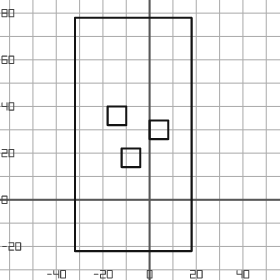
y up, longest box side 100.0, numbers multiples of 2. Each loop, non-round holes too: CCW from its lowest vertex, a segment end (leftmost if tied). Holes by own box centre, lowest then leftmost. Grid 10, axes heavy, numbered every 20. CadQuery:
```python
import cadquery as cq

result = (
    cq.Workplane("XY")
    .moveTo(-32.0, -22.0)
    .lineTo(18.0, -22.0)
    .lineTo(18.0, 78.0)
    .lineTo(-32.0, 78.0)
    .close()
    .moveTo(-12.0, 14.0)
    .lineTo(-4.0, 14.0)
    .lineTo(-4.0, 22.0)
    .lineTo(-12.0, 22.0)
    .close()
    .moveTo(0.0, 26.0)
    .lineTo(8.0, 26.0)
    .lineTo(8.0, 34.0)
    .lineTo(0.0, 34.0)
    .close()
    .moveTo(-18.0, 32.0)
    .lineTo(-10.0, 32.0)
    .lineTo(-10.0, 40.0)
    .lineTo(-18.0, 40.0)
    .close()
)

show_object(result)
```